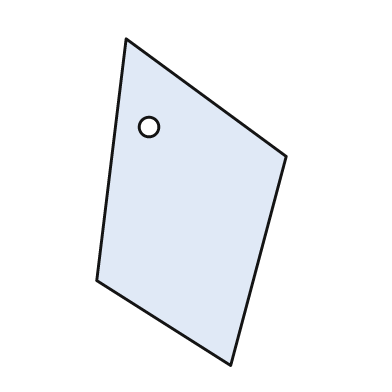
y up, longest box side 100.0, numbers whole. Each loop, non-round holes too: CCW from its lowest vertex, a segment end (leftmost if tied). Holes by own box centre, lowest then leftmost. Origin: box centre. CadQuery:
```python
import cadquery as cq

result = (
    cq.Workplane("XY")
    .moveTo(12.0, -50.0)
    .lineTo(29.0, 14.0)
    .lineTo(-20.0, 50.0)
    .lineTo(-29.0, -24.0)
    .close()
    .moveTo(-13.0, 23.0)
    .circle(3.0)
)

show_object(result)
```